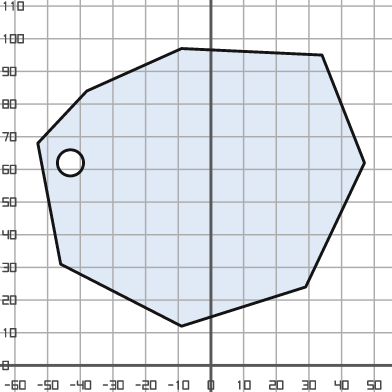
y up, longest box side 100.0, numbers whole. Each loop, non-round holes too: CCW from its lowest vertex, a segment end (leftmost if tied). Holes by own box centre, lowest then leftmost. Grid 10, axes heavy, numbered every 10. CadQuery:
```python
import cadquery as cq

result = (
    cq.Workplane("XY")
    .moveTo(-9.0, 12.0)
    .lineTo(29.0, 24.0)
    .lineTo(47.0, 62.0)
    .lineTo(34.0, 95.0)
    .lineTo(-9.0, 97.0)
    .lineTo(-38.0, 84.0)
    .lineTo(-53.0, 68.0)
    .lineTo(-46.0, 31.0)
    .close()
    .moveTo(-43.0, 62.0)
    .circle(4.0)
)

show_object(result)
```